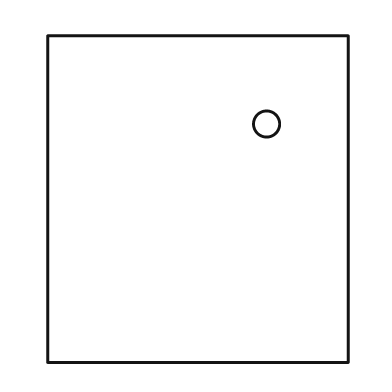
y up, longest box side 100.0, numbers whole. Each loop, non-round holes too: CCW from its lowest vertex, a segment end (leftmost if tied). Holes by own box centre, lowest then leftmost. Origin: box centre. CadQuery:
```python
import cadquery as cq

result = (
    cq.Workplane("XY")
    .moveTo(-46.0, -50.0)
    .lineTo(46.0, -50.0)
    .lineTo(46.0, 50.0)
    .lineTo(-46.0, 50.0)
    .close()
    .moveTo(21.0, 23.0)
    .circle(4.0)
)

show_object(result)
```